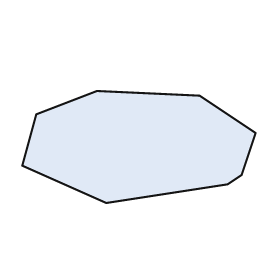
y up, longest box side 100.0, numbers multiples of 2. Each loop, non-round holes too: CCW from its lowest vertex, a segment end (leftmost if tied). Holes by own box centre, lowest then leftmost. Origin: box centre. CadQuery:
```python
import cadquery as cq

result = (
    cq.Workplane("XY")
    .moveTo(-14.0, -24.0)
    .lineTo(38.0, -16.0)
    .lineTo(44.0, -12.0)
    .lineTo(50.0, 6.0)
    .lineTo(26.0, 22.0)
    .lineTo(-18.0, 24.0)
    .lineTo(-44.0, 14.0)
    .lineTo(-50.0, -8.0)
    .close()
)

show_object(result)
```